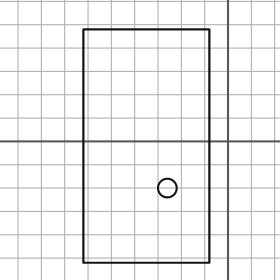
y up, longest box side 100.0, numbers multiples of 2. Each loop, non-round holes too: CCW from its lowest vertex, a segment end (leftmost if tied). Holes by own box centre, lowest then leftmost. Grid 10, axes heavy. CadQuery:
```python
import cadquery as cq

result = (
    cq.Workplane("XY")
    .moveTo(-62.0, -52.0)
    .lineTo(-8.0, -52.0)
    .lineTo(-8.0, 48.0)
    .lineTo(-62.0, 48.0)
    .close()
    .moveTo(-26.0, -20.0)
    .circle(4.0)
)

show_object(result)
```